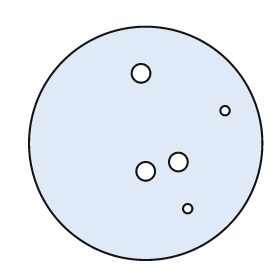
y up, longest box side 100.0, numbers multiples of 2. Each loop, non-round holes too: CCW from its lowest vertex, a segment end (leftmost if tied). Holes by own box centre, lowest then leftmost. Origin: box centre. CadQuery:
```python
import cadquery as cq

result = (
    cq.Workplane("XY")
    .moveTo(0.0, 0.0)
    .circle(50.0)
    .moveTo(18.0, -28.0)
    .circle(2.0)
    .moveTo(0.0, -12.0)
    .circle(4.0)
    .moveTo(14.0, -8.0)
    .circle(4.0)
    .moveTo(34.0, 14.0)
    .circle(2.0)
    .moveTo(-2.0, 30.0)
    .circle(4.0)
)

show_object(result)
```